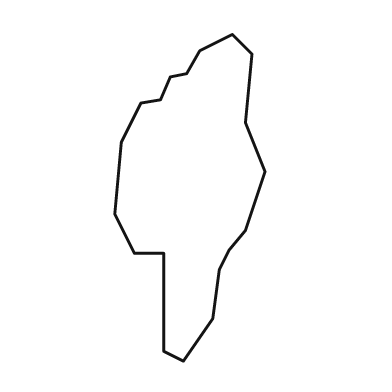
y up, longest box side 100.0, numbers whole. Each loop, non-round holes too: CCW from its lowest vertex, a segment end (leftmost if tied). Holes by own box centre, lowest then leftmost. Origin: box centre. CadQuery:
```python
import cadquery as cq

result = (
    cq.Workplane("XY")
    .moveTo(-2.0, -50.0)
    .lineTo(7.0, -37.0)
    .lineTo(9.0, -22.0)
    .lineTo(12.0, -16.0)
    .lineTo(17.0, -10.0)
    .lineTo(23.0, 8.0)
    .lineTo(17.0, 23.0)
    .lineTo(19.0, 44.0)
    .lineTo(13.0, 50.0)
    .lineTo(3.0, 45.0)
    .lineTo(-1.0, 38.0)
    .lineTo(-6.0, 37.0)
    .lineTo(-9.0, 30.0)
    .lineTo(-15.0, 29.0)
    .lineTo(-21.0, 17.0)
    .lineTo(-23.0, -5.0)
    .lineTo(-17.0, -17.0)
    .lineTo(-8.0, -17.0)
    .lineTo(-8.0, -47.0)
    .close()
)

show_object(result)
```